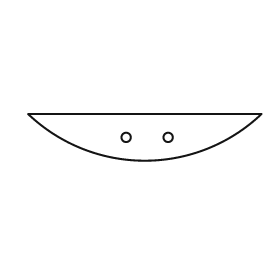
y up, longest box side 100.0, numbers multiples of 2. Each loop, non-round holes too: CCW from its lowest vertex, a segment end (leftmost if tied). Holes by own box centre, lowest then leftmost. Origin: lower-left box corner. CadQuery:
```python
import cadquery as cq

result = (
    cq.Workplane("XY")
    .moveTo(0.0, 20.0)
    .threePointArc((50.0, 0.0), (100.0, 20.0))
    .close()
    .moveTo(42.0, 10.0)
    .circle(2.0)
    .moveTo(60.0, 10.0)
    .circle(2.0)
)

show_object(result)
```